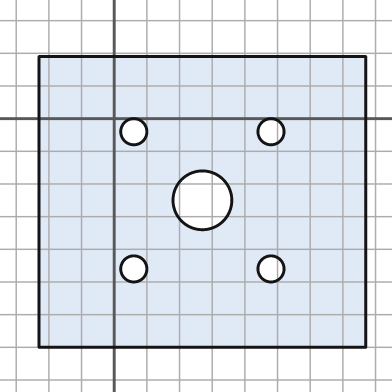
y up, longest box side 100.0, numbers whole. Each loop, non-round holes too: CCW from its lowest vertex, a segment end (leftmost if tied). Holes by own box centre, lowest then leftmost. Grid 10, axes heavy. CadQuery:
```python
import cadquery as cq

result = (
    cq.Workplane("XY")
    .moveTo(-23.0, -70.0)
    .lineTo(77.0, -70.0)
    .lineTo(77.0, 19.0)
    .lineTo(-23.0, 19.0)
    .close()
    .moveTo(6.0, -46.0)
    .circle(4.0)
    .moveTo(48.0, -46.0)
    .circle(4.0)
    .moveTo(27.0, -25.0)
    .circle(9.0)
    .moveTo(6.0, -4.0)
    .circle(4.0)
    .moveTo(48.0, -4.0)
    .circle(4.0)
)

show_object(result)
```